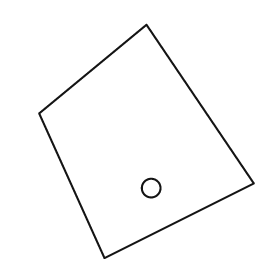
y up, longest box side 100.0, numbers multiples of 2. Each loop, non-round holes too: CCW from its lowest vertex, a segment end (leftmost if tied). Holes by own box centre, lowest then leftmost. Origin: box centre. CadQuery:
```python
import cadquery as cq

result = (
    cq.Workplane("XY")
    .moveTo(-18.0, -50.0)
    .lineTo(46.0, -18.0)
    .lineTo(0.0, 50.0)
    .lineTo(-46.0, 12.0)
    .close()
    .moveTo(2.0, -20.0)
    .circle(4.0)
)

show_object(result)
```